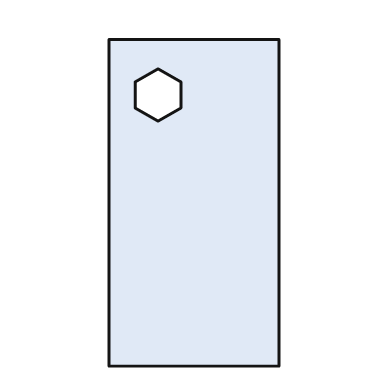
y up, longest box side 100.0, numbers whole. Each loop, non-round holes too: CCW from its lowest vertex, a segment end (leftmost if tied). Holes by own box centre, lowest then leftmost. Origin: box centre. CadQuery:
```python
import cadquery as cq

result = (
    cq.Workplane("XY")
    .moveTo(-26.0, -50.0)
    .lineTo(26.0, -50.0)
    .lineTo(26.0, 50.0)
    .lineTo(-26.0, 50.0)
    .close()
    .moveTo(-11.0, 25.0)
    .lineTo(-4.0, 29.0)
    .lineTo(-4.0, 37.0)
    .lineTo(-11.0, 41.0)
    .lineTo(-18.0, 37.0)
    .lineTo(-18.0, 29.0)
    .close()
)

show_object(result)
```